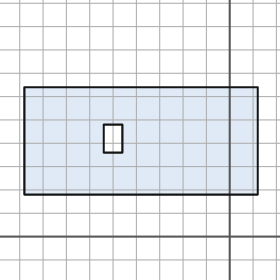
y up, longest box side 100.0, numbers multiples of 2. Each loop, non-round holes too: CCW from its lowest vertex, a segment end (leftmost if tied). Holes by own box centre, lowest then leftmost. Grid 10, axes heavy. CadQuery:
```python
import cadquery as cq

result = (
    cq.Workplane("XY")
    .moveTo(-88.0, 18.0)
    .lineTo(12.0, 18.0)
    .lineTo(12.0, 64.0)
    .lineTo(-88.0, 64.0)
    .close()
    .moveTo(-54.0, 36.0)
    .lineTo(-46.0, 36.0)
    .lineTo(-46.0, 48.0)
    .lineTo(-54.0, 48.0)
    .close()
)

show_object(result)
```